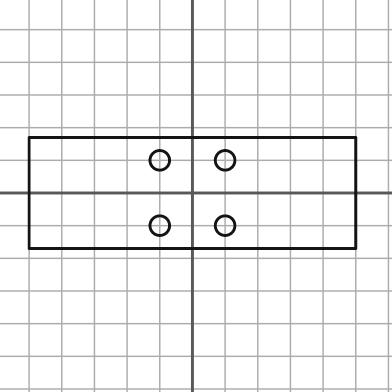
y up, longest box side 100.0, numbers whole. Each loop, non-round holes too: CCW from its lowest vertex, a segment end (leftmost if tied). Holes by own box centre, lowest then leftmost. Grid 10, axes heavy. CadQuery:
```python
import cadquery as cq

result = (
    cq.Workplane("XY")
    .moveTo(-50.0, -17.0)
    .lineTo(50.0, -17.0)
    .lineTo(50.0, 17.0)
    .lineTo(-50.0, 17.0)
    .close()
    .moveTo(-10.0, -10.0)
    .circle(3.0)
    .moveTo(10.0, -10.0)
    .circle(3.0)
    .moveTo(-10.0, 10.0)
    .circle(3.0)
    .moveTo(10.0, 10.0)
    .circle(3.0)
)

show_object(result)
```